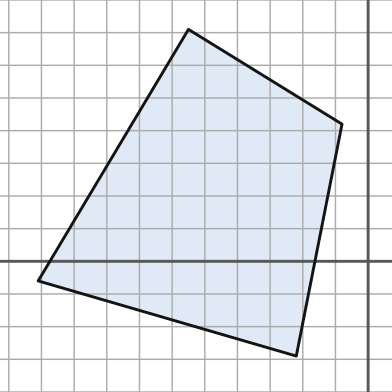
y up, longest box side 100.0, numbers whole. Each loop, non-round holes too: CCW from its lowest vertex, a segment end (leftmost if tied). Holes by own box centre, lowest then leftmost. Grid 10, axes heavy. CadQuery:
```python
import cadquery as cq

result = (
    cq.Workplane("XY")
    .moveTo(-22.0, -29.0)
    .lineTo(-8.0, 42.0)
    .lineTo(-55.0, 71.0)
    .lineTo(-101.0, -6.0)
    .close()
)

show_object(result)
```